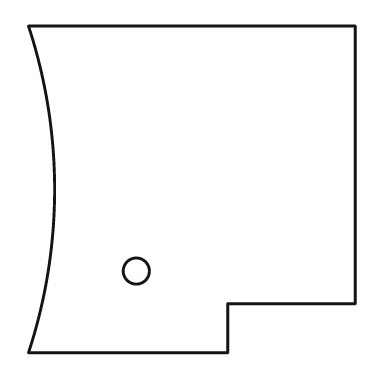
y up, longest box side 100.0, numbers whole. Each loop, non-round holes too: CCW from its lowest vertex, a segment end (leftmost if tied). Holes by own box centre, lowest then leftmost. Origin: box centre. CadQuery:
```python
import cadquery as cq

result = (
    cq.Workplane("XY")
    .moveTo(-50.0, -50.0)
    .lineTo(11.0, -50.0)
    .lineTo(11.0, -35.0)
    .lineTo(50.0, -35.0)
    .lineTo(50.0, 50.0)
    .lineTo(-50.0, 50.0)
    .threePointArc((-42.0, 0.0), (-50.0, -50.0))
    .close()
    .moveTo(-17.0, -25.0)
    .circle(4.0)
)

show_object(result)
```